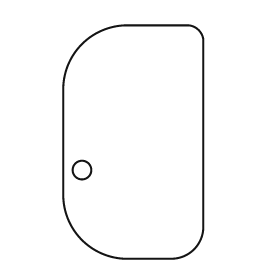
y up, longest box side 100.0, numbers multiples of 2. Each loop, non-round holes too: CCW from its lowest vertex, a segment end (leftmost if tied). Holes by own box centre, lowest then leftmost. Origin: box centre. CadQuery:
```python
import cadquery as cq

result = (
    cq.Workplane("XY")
    .moveTo(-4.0, -50.0)
    .lineTo(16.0, -50.0)
    .threePointArc((26.0, -46.0), (30.0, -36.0))
    .lineTo(30.0, 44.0)
    .threePointArc((28.0, 48.0), (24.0, 50.0))
    .lineTo(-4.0, 50.0)
    .threePointArc((-22.0, 42.0), (-30.0, 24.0))
    .lineTo(-30.0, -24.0)
    .threePointArc((-22.0, -42.0), (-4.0, -50.0))
    .close()
    .moveTo(-22.0, -12.0)
    .circle(4.0)
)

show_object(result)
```